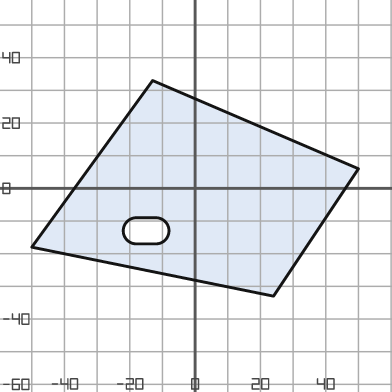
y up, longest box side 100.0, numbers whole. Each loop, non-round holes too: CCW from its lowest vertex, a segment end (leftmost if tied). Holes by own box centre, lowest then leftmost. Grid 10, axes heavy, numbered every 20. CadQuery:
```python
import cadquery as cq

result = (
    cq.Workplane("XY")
    .moveTo(24.0, -33.0)
    .lineTo(50.0, 6.0)
    .lineTo(-13.0, 33.0)
    .lineTo(-50.0, -18.0)
    .close()
    .moveTo(-18.0, -17.0)
    .lineTo(-12.0, -17.0)
    .threePointArc((-8.0, -13.0), (-12.0, -9.0))
    .lineTo(-18.0, -9.0)
    .threePointArc((-22.0, -13.0), (-18.0, -17.0))
    .close()
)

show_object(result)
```